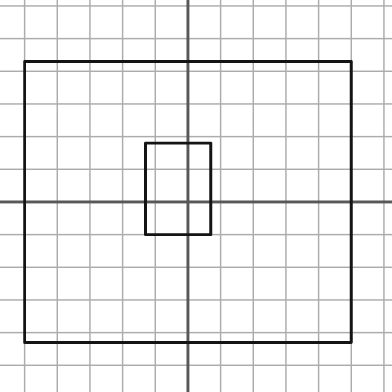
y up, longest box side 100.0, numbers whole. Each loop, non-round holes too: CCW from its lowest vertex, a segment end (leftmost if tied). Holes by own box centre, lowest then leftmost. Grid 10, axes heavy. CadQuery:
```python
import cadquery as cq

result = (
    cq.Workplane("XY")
    .moveTo(-50.0, -43.0)
    .lineTo(50.0, -43.0)
    .lineTo(50.0, 43.0)
    .lineTo(-50.0, 43.0)
    .close()
    .moveTo(-13.0, -10.0)
    .lineTo(7.0, -10.0)
    .lineTo(7.0, 18.0)
    .lineTo(-13.0, 18.0)
    .close()
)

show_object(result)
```